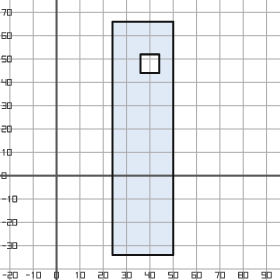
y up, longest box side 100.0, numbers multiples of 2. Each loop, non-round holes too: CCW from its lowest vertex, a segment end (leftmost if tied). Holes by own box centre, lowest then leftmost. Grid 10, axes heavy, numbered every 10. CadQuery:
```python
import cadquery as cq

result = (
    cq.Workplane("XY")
    .moveTo(24.0, -34.0)
    .lineTo(50.0, -34.0)
    .lineTo(50.0, 66.0)
    .lineTo(24.0, 66.0)
    .close()
    .moveTo(36.0, 44.0)
    .lineTo(44.0, 44.0)
    .lineTo(44.0, 52.0)
    .lineTo(36.0, 52.0)
    .close()
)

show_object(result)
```